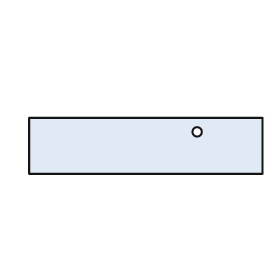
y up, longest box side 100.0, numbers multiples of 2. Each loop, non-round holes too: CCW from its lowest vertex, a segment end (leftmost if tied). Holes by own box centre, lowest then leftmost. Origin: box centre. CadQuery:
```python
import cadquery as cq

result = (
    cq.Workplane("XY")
    .moveTo(-50.0, -12.0)
    .lineTo(50.0, -12.0)
    .lineTo(50.0, 12.0)
    .lineTo(-50.0, 12.0)
    .close()
    .moveTo(22.0, 6.0)
    .circle(2.0)
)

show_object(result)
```